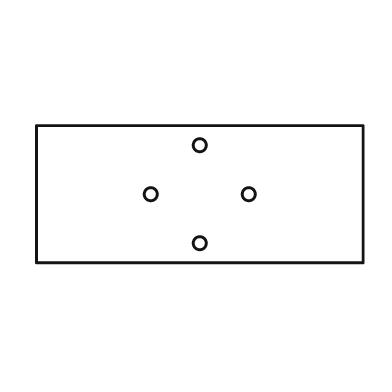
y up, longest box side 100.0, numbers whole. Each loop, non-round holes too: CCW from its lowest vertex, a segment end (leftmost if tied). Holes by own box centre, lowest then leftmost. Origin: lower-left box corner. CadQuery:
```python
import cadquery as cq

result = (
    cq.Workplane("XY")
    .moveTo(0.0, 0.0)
    .lineTo(100.0, 0.0)
    .lineTo(100.0, 42.0)
    .lineTo(0.0, 42.0)
    .close()
    .moveTo(50.0, 6.0)
    .circle(2.0)
    .moveTo(35.0, 21.0)
    .circle(2.0)
    .moveTo(65.0, 21.0)
    .circle(2.0)
    .moveTo(50.0, 36.0)
    .circle(2.0)
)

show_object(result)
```